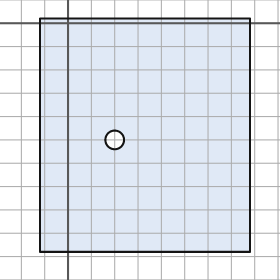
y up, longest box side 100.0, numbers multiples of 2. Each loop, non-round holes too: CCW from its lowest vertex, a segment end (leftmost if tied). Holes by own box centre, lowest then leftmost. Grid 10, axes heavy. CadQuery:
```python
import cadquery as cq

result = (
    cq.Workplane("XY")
    .moveTo(-12.0, -98.0)
    .lineTo(78.0, -98.0)
    .lineTo(78.0, 2.0)
    .lineTo(-12.0, 2.0)
    .close()
    .moveTo(20.0, -50.0)
    .circle(4.0)
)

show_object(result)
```